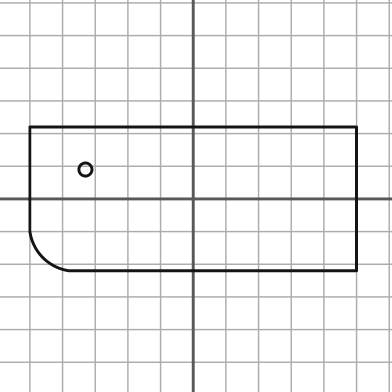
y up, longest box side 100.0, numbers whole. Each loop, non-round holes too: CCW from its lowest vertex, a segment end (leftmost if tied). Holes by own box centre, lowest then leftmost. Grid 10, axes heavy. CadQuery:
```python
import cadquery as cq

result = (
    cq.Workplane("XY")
    .moveTo(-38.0, -22.0)
    .lineTo(50.0, -22.0)
    .lineTo(50.0, 22.0)
    .lineTo(-50.0, 22.0)
    .lineTo(-50.0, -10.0)
    .threePointArc((-46.0, -18.0), (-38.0, -22.0))
    .close()
    .moveTo(-33.0, 9.0)
    .circle(2.0)
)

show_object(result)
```